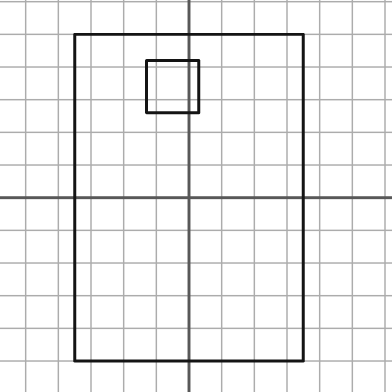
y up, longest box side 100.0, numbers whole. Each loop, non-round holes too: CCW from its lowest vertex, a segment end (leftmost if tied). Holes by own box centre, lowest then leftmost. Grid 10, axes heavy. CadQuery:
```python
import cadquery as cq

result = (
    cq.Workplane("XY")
    .moveTo(-35.0, -50.0)
    .lineTo(35.0, -50.0)
    .lineTo(35.0, 50.0)
    .lineTo(-35.0, 50.0)
    .close()
    .moveTo(-13.0, 26.0)
    .lineTo(3.0, 26.0)
    .lineTo(3.0, 42.0)
    .lineTo(-13.0, 42.0)
    .close()
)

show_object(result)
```